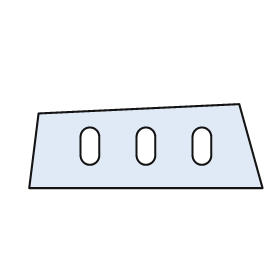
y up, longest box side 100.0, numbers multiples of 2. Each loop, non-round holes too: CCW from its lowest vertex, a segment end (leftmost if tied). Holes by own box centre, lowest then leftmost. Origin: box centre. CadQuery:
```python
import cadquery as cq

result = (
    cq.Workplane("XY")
    .moveTo(-50.0, -18.0)
    .lineTo(50.0, -18.0)
    .lineTo(40.0, 18.0)
    .lineTo(-46.0, 14.0)
    .close()
    .moveTo(-28.0, -4.0)
    .threePointArc((-24.0, -8.0), (-20.0, -4.0))
    .lineTo(-20.0, 4.0)
    .threePointArc((-24.0, 8.0), (-28.0, 4.0))
    .close()
    .moveTo(-4.0, -4.0)
    .threePointArc((0.0, -8.0), (4.0, -4.0))
    .lineTo(4.0, 4.0)
    .threePointArc((0.0, 8.0), (-4.0, 4.0))
    .close()
    .moveTo(20.0, -4.0)
    .threePointArc((24.0, -8.0), (28.0, -4.0))
    .lineTo(28.0, 4.0)
    .threePointArc((24.0, 8.0), (20.0, 4.0))
    .close()
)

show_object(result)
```